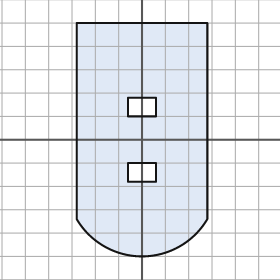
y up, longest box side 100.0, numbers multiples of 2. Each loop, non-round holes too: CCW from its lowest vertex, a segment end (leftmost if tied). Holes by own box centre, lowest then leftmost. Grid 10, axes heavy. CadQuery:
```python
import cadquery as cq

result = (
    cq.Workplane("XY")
    .moveTo(-28.0, -34.0)
    .threePointArc((0.0, -50.0), (28.0, -34.0))
    .lineTo(28.0, 50.0)
    .lineTo(-28.0, 50.0)
    .close()
    .moveTo(-6.0, -18.0)
    .lineTo(6.0, -18.0)
    .lineTo(6.0, -10.0)
    .lineTo(-6.0, -10.0)
    .close()
    .moveTo(-6.0, 10.0)
    .lineTo(6.0, 10.0)
    .lineTo(6.0, 18.0)
    .lineTo(-6.0, 18.0)
    .close()
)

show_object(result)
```